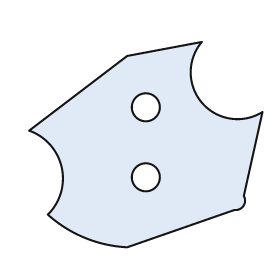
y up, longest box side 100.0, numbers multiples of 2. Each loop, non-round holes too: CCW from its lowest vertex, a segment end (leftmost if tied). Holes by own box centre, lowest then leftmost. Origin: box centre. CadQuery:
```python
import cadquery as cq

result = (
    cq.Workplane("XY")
    .moveTo(-8.0, -44.0)
    .lineTo(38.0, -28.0)
    .threePointArc((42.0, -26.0), (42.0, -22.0))
    .lineTo(50.0, 14.0)
    .threePointArc((24.0, 18.0), (24.0, 44.0))
    .lineTo(-8.0, 38.0)
    .lineTo(-50.0, 6.0)
    .threePointArc((-36.0, -10.0), (-42.0, -30.0))
    .threePointArc((-26.0, -40.0), (-8.0, -44.0))
    .close()
    .moveTo(0.0, -14.0)
    .circle(6.0)
    .moveTo(0.0, 16.0)
    .circle(6.0)
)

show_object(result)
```